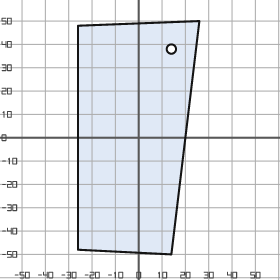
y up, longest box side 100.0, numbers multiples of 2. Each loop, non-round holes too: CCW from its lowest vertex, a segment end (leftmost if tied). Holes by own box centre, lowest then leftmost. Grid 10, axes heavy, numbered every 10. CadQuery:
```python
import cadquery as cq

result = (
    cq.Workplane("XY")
    .moveTo(14.0, -50.0)
    .lineTo(26.0, 50.0)
    .lineTo(-26.0, 48.0)
    .lineTo(-26.0, -48.0)
    .close()
    .moveTo(14.0, 38.0)
    .circle(2.0)
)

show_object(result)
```